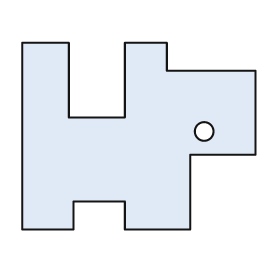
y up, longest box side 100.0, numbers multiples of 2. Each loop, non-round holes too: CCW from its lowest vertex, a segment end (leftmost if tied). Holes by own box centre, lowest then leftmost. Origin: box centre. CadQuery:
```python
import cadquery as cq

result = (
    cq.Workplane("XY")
    .moveTo(-50.0, -40.0)
    .lineTo(-28.0, -40.0)
    .lineTo(-28.0, -28.0)
    .lineTo(-6.0, -28.0)
    .lineTo(-6.0, -40.0)
    .lineTo(22.0, -40.0)
    .lineTo(22.0, -8.0)
    .lineTo(50.0, -8.0)
    .lineTo(50.0, 28.0)
    .lineTo(12.0, 28.0)
    .lineTo(12.0, 40.0)
    .lineTo(-6.0, 40.0)
    .lineTo(-6.0, 8.0)
    .lineTo(-30.0, 8.0)
    .lineTo(-30.0, 40.0)
    .lineTo(-50.0, 40.0)
    .close()
    .moveTo(28.0, 2.0)
    .circle(4.0)
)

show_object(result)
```